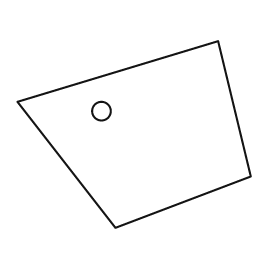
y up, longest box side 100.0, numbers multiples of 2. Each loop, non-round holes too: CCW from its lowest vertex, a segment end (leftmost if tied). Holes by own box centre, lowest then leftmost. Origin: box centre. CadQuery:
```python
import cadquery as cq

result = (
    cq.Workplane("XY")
    .moveTo(-8.0, -40.0)
    .lineTo(50.0, -18.0)
    .lineTo(36.0, 40.0)
    .lineTo(-50.0, 14.0)
    .close()
    .moveTo(-14.0, 10.0)
    .circle(4.0)
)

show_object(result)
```